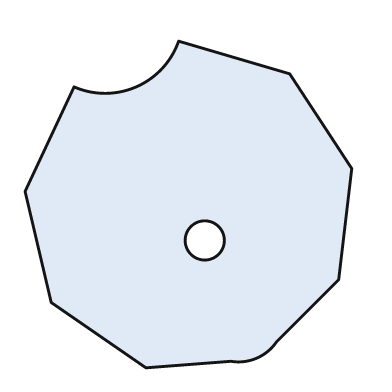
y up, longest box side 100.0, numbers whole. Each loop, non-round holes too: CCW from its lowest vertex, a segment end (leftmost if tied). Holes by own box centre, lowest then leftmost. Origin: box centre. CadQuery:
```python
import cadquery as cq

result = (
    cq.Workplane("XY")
    .moveTo(-13.0, -50.0)
    .lineTo(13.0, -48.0)
    .threePointArc((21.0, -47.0), (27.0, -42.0))
    .lineTo(46.0, -23.0)
    .lineTo(50.0, 11.0)
    .lineTo(31.0, 40.0)
    .lineTo(-3.0, 50.0)
    .threePointArc((-16.0, 36.0), (-35.0, 36.0))
    .lineTo(-50.0, 4.0)
    .lineTo(-42.0, -30.0)
    .close()
    .moveTo(5.0, -11.0)
    .circle(6.0)
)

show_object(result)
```